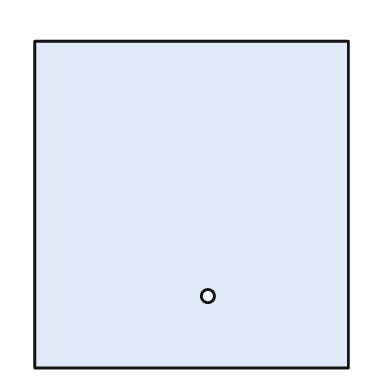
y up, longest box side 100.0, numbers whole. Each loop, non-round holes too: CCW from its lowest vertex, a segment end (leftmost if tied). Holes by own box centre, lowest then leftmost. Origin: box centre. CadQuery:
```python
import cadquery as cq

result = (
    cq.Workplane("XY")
    .moveTo(-48.0, -50.0)
    .lineTo(48.0, -50.0)
    .lineTo(48.0, 50.0)
    .lineTo(-48.0, 50.0)
    .close()
    .moveTo(5.0, -28.0)
    .circle(2.0)
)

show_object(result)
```